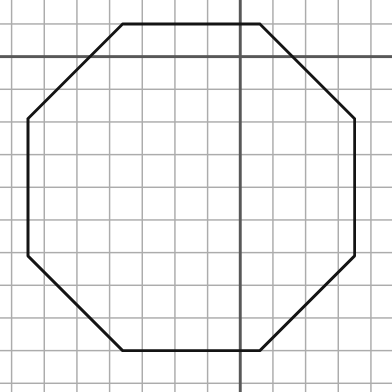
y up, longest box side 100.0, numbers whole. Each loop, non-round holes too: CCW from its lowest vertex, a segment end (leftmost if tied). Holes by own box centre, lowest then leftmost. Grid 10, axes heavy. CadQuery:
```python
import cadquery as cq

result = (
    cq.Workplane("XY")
    .moveTo(-36.0, -90.0)
    .lineTo(6.0, -90.0)
    .lineTo(35.0, -61.0)
    .lineTo(35.0, -19.0)
    .lineTo(6.0, 10.0)
    .lineTo(-36.0, 10.0)
    .lineTo(-65.0, -19.0)
    .lineTo(-65.0, -61.0)
    .close()
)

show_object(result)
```